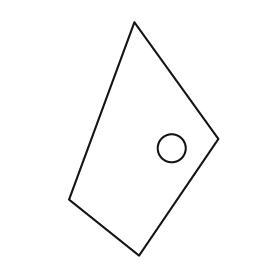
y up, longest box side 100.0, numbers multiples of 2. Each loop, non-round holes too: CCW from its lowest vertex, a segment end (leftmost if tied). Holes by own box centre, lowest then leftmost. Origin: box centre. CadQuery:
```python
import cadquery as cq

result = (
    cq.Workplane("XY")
    .moveTo(-2.0, -50.0)
    .lineTo(32.0, 0.0)
    .lineTo(-4.0, 50.0)
    .lineTo(-32.0, -26.0)
    .close()
    .moveTo(12.0, -4.0)
    .circle(6.0)
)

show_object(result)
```